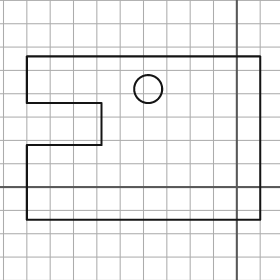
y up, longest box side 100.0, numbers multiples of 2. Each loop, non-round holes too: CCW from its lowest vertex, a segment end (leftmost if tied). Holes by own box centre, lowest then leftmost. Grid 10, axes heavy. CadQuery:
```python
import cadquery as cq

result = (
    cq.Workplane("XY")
    .moveTo(-90.0, -14.0)
    .lineTo(10.0, -14.0)
    .lineTo(10.0, 56.0)
    .lineTo(-90.0, 56.0)
    .lineTo(-90.0, 36.0)
    .lineTo(-58.0, 36.0)
    .lineTo(-58.0, 18.0)
    .lineTo(-90.0, 18.0)
    .close()
    .moveTo(-38.0, 42.0)
    .circle(6.0)
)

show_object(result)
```